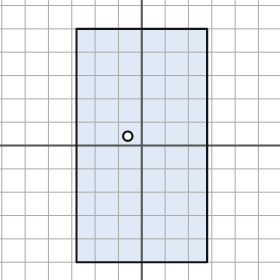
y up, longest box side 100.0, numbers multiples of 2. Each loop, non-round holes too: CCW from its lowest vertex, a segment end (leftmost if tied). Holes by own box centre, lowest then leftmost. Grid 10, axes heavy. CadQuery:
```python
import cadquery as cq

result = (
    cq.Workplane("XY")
    .moveTo(-28.0, -50.0)
    .lineTo(28.0, -50.0)
    .lineTo(28.0, 50.0)
    .lineTo(-28.0, 50.0)
    .close()
    .moveTo(-6.0, 4.0)
    .circle(2.0)
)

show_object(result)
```